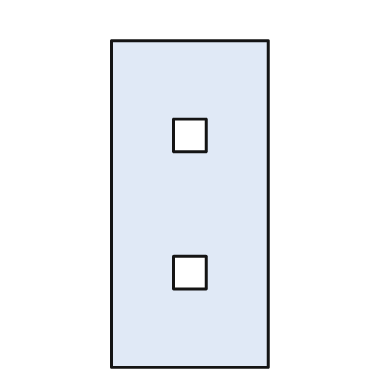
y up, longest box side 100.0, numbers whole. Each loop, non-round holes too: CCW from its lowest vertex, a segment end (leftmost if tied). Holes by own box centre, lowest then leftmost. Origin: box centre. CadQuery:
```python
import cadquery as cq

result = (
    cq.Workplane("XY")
    .moveTo(-24.0, -50.0)
    .lineTo(24.0, -50.0)
    .lineTo(24.0, 50.0)
    .lineTo(-24.0, 50.0)
    .close()
    .moveTo(-5.0, -26.0)
    .lineTo(5.0, -26.0)
    .lineTo(5.0, -16.0)
    .lineTo(-5.0, -16.0)
    .close()
    .moveTo(-5.0, 16.0)
    .lineTo(5.0, 16.0)
    .lineTo(5.0, 26.0)
    .lineTo(-5.0, 26.0)
    .close()
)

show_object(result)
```